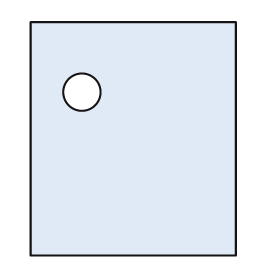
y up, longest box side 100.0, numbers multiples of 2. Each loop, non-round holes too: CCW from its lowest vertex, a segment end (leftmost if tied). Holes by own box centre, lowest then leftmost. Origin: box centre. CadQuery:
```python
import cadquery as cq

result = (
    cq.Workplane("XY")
    .moveTo(-44.0, -50.0)
    .lineTo(44.0, -50.0)
    .lineTo(44.0, 50.0)
    .lineTo(-44.0, 50.0)
    .close()
    .moveTo(-22.0, 20.0)
    .circle(8.0)
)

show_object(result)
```